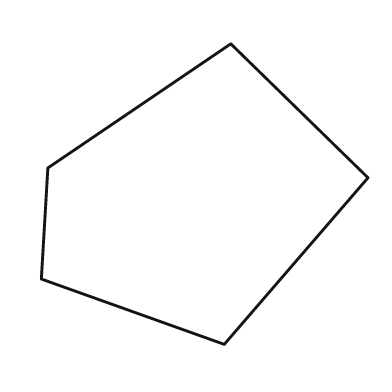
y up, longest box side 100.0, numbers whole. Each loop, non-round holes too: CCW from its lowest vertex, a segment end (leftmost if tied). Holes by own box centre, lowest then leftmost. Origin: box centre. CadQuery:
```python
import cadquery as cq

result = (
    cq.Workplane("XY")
    .moveTo(6.0, -46.0)
    .lineTo(50.0, 5.0)
    .lineTo(8.0, 46.0)
    .lineTo(-48.0, 8.0)
    .lineTo(-50.0, -26.0)
    .close()
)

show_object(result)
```